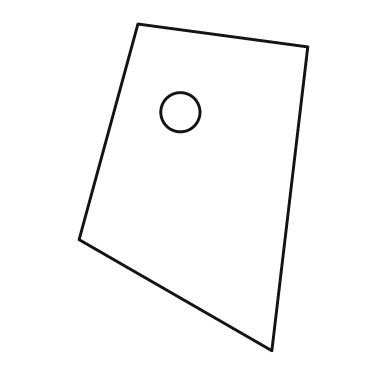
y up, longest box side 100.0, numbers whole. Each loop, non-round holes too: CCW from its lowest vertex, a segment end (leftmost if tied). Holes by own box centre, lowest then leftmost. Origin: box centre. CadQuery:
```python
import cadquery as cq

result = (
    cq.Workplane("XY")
    .moveTo(24.0, -50.0)
    .lineTo(35.0, 43.0)
    .lineTo(-17.0, 50.0)
    .lineTo(-35.0, -16.0)
    .close()
    .moveTo(-4.0, 23.0)
    .circle(6.0)
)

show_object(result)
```